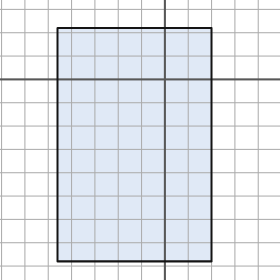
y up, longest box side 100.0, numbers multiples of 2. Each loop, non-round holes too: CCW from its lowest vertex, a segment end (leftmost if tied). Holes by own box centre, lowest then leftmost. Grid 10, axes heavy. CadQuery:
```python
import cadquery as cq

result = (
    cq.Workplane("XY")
    .moveTo(-46.0, -78.0)
    .lineTo(20.0, -78.0)
    .lineTo(20.0, 22.0)
    .lineTo(-46.0, 22.0)
    .close()
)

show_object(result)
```